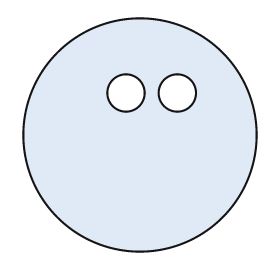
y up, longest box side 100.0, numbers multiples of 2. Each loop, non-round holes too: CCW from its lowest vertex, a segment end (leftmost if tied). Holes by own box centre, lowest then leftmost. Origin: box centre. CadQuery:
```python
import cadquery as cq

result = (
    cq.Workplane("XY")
    .moveTo(0.0, 0.0)
    .circle(50.0)
    .moveTo(-6.0, 18.0)
    .circle(8.0)
    .moveTo(16.0, 18.0)
    .circle(8.0)
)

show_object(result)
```